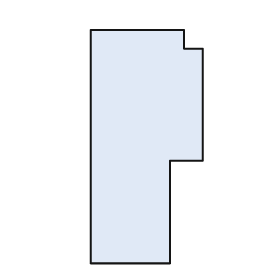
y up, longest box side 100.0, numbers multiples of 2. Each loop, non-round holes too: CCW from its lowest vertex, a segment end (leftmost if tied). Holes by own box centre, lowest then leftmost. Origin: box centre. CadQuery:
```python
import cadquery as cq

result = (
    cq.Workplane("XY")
    .moveTo(-24.0, -50.0)
    .lineTo(10.0, -50.0)
    .lineTo(10.0, -6.0)
    .lineTo(24.0, -6.0)
    .lineTo(24.0, 42.0)
    .lineTo(16.0, 42.0)
    .lineTo(16.0, 50.0)
    .lineTo(-24.0, 50.0)
    .close()
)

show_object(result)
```